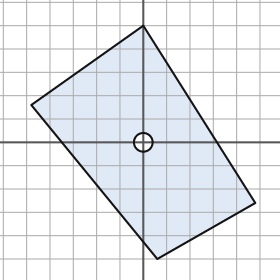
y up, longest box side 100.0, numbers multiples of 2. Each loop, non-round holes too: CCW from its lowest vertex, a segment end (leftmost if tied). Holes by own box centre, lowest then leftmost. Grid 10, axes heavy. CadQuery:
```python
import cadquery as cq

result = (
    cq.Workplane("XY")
    .moveTo(6.0, -50.0)
    .lineTo(48.0, -26.0)
    .lineTo(0.0, 50.0)
    .lineTo(-48.0, 16.0)
    .close()
    .moveTo(0.0, 0.0)
    .circle(4.0)
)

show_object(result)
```